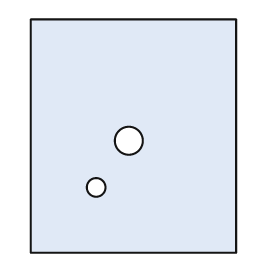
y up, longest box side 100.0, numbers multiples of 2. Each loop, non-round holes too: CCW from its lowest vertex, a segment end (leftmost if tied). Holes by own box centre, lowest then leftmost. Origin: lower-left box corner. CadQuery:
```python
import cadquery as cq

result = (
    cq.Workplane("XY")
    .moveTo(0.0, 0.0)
    .lineTo(88.0, 0.0)
    .lineTo(88.0, 100.0)
    .lineTo(0.0, 100.0)
    .close()
    .moveTo(28.0, 28.0)
    .circle(4.0)
    .moveTo(42.0, 48.0)
    .circle(6.0)
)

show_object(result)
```